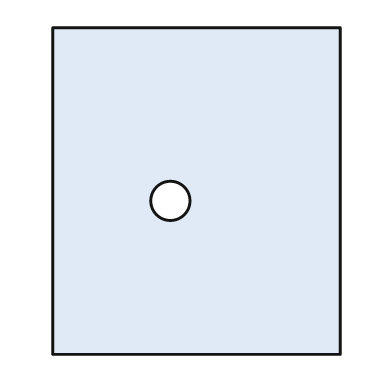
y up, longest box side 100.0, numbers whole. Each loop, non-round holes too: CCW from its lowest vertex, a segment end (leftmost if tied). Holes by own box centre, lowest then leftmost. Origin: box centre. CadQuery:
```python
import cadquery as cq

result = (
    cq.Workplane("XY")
    .moveTo(-44.0, -50.0)
    .lineTo(44.0, -50.0)
    .lineTo(44.0, 50.0)
    .lineTo(-44.0, 50.0)
    .close()
    .moveTo(-8.0, -3.0)
    .circle(6.0)
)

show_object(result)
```